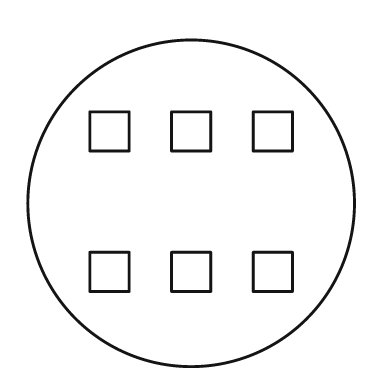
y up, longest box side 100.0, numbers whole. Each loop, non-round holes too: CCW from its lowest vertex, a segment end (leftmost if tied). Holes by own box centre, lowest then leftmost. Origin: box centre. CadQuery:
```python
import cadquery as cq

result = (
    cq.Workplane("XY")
    .moveTo(0.0, 0.0)
    .circle(50.0)
    .moveTo(-31.0, -27.0)
    .lineTo(-19.0, -27.0)
    .lineTo(-19.0, -15.0)
    .lineTo(-31.0, -15.0)
    .close()
    .moveTo(-6.0, -27.0)
    .lineTo(6.0, -27.0)
    .lineTo(6.0, -15.0)
    .lineTo(-6.0, -15.0)
    .close()
    .moveTo(19.0, -27.0)
    .lineTo(31.0, -27.0)
    .lineTo(31.0, -15.0)
    .lineTo(19.0, -15.0)
    .close()
    .moveTo(-31.0, 16.0)
    .lineTo(-19.0, 16.0)
    .lineTo(-19.0, 28.0)
    .lineTo(-31.0, 28.0)
    .close()
    .moveTo(-6.0, 16.0)
    .lineTo(6.0, 16.0)
    .lineTo(6.0, 28.0)
    .lineTo(-6.0, 28.0)
    .close()
    .moveTo(19.0, 16.0)
    .lineTo(31.0, 16.0)
    .lineTo(31.0, 28.0)
    .lineTo(19.0, 28.0)
    .close()
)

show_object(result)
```